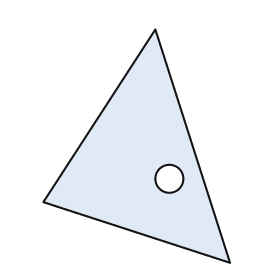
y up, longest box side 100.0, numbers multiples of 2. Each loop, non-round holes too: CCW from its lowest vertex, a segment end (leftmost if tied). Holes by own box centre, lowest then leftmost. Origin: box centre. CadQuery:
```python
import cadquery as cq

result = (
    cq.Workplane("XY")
    .moveTo(40.0, -50.0)
    .lineTo(8.0, 50.0)
    .lineTo(-40.0, -24.0)
    .close()
    .moveTo(14.0, -14.0)
    .circle(6.0)
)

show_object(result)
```